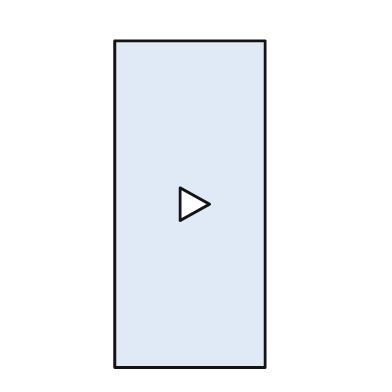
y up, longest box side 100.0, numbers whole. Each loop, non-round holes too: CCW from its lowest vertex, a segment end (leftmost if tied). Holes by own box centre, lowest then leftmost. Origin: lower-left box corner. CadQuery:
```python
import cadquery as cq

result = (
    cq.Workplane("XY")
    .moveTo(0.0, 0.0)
    .lineTo(46.0, 0.0)
    .lineTo(46.0, 100.0)
    .lineTo(0.0, 100.0)
    .close()
    .moveTo(20.0, 45.0)
    .lineTo(29.0, 50.0)
    .lineTo(20.0, 55.0)
    .close()
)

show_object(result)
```